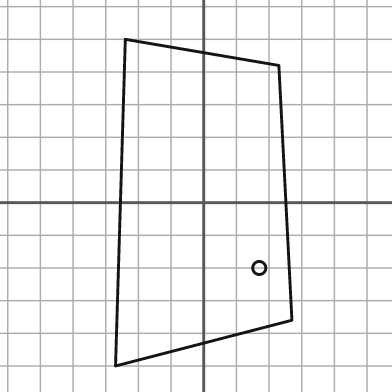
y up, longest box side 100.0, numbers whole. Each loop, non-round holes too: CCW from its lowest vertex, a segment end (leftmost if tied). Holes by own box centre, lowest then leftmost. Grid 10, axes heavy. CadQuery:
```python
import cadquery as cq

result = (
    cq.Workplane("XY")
    .moveTo(-27.0, -50.0)
    .lineTo(27.0, -36.0)
    .lineTo(23.0, 42.0)
    .lineTo(-24.0, 50.0)
    .close()
    .moveTo(17.0, -20.0)
    .circle(2.0)
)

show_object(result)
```